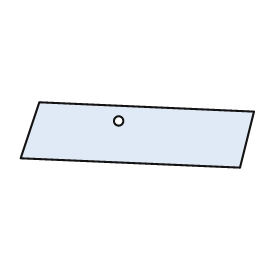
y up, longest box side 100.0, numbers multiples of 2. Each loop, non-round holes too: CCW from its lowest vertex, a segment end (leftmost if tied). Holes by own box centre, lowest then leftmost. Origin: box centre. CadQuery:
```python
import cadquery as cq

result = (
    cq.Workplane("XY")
    .moveTo(44.0, -14.0)
    .lineTo(50.0, 10.0)
    .lineTo(-42.0, 14.0)
    .lineTo(-50.0, -10.0)
    .close()
    .moveTo(-8.0, 6.0)
    .circle(2.0)
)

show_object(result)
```